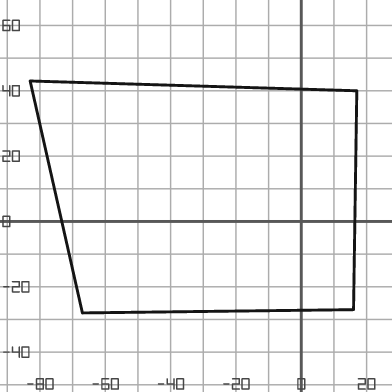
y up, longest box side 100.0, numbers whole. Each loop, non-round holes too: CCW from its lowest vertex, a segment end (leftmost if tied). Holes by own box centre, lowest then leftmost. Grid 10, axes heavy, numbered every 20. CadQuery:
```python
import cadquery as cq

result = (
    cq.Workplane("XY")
    .moveTo(-67.0, -28.0)
    .lineTo(16.0, -27.0)
    .lineTo(17.0, 40.0)
    .lineTo(-83.0, 43.0)
    .close()
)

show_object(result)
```